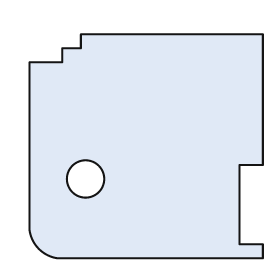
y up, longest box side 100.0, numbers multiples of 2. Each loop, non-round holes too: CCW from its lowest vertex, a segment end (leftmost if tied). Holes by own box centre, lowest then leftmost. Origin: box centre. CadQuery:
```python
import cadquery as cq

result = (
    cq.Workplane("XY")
    .moveTo(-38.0, -48.0)
    .lineTo(50.0, -48.0)
    .lineTo(50.0, -42.0)
    .lineTo(40.0, -42.0)
    .lineTo(40.0, -8.0)
    .lineTo(50.0, -8.0)
    .lineTo(50.0, 48.0)
    .lineTo(-28.0, 48.0)
    .lineTo(-28.0, 42.0)
    .lineTo(-36.0, 42.0)
    .lineTo(-36.0, 36.0)
    .lineTo(-50.0, 36.0)
    .lineTo(-50.0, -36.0)
    .threePointArc((-46.0, -44.0), (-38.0, -48.0))
    .close()
    .moveTo(-26.0, -14.0)
    .circle(8.0)
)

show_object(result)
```